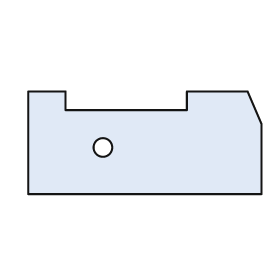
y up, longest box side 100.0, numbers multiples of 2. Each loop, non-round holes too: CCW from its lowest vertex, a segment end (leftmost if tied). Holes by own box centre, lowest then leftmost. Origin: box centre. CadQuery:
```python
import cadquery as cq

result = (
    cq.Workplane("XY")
    .moveTo(-50.0, -22.0)
    .lineTo(50.0, -22.0)
    .lineTo(50.0, 8.0)
    .lineTo(44.0, 22.0)
    .lineTo(18.0, 22.0)
    .lineTo(18.0, 14.0)
    .lineTo(-34.0, 14.0)
    .lineTo(-34.0, 22.0)
    .lineTo(-50.0, 22.0)
    .close()
    .moveTo(-18.0, -2.0)
    .circle(4.0)
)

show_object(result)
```